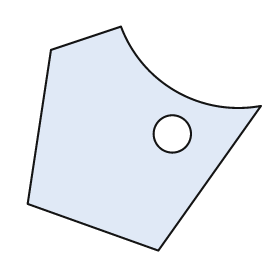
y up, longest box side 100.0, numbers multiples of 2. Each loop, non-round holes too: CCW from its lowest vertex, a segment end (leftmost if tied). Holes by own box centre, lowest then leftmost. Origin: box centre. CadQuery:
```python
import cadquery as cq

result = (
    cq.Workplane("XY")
    .moveTo(6.0, -48.0)
    .lineTo(50.0, 14.0)
    .threePointArc((14.0, 20.0), (-10.0, 48.0))
    .lineTo(-40.0, 38.0)
    .lineTo(-50.0, -28.0)
    .close()
    .moveTo(12.0, 2.0)
    .circle(8.0)
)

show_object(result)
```